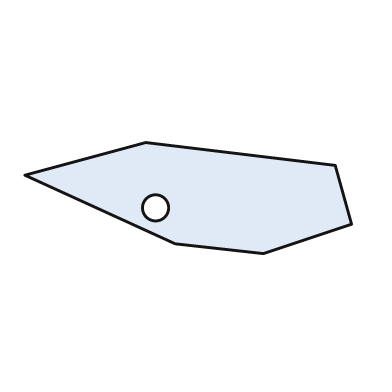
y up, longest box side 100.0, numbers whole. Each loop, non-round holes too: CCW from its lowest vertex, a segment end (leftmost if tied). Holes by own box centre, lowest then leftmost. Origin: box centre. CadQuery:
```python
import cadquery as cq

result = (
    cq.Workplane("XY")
    .moveTo(23.0, -17.0)
    .lineTo(50.0, -8.0)
    .lineTo(45.0, 10.0)
    .lineTo(-13.0, 17.0)
    .lineTo(-50.0, 7.0)
    .lineTo(-4.0, -14.0)
    .close()
    .moveTo(-10.0, -3.0)
    .circle(4.0)
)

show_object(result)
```